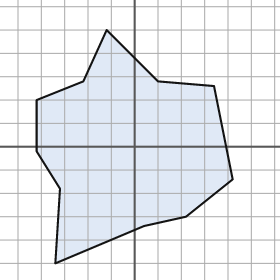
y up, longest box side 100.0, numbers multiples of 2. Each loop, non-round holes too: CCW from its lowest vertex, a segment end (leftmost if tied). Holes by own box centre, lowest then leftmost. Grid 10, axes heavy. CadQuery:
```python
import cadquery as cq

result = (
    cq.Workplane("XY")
    .moveTo(-34.0, -50.0)
    .lineTo(4.0, -34.0)
    .lineTo(22.0, -30.0)
    .lineTo(42.0, -14.0)
    .lineTo(34.0, 26.0)
    .lineTo(10.0, 28.0)
    .lineTo(-12.0, 50.0)
    .lineTo(-22.0, 28.0)
    .lineTo(-42.0, 20.0)
    .lineTo(-42.0, -2.0)
    .lineTo(-32.0, -18.0)
    .close()
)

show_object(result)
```